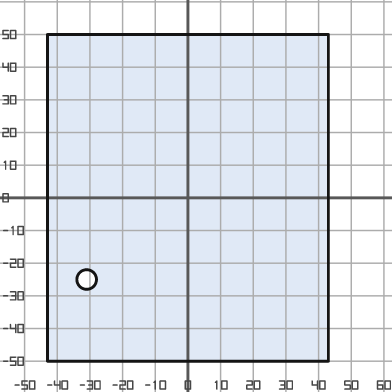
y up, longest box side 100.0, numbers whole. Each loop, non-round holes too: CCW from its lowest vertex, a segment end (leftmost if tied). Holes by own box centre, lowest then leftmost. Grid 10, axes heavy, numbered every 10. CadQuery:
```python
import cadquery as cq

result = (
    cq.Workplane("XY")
    .moveTo(-43.0, -50.0)
    .lineTo(43.0, -50.0)
    .lineTo(43.0, 50.0)
    .lineTo(-43.0, 50.0)
    .close()
    .moveTo(-31.0, -25.0)
    .circle(3.0)
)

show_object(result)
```